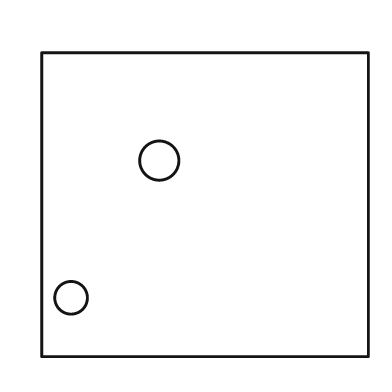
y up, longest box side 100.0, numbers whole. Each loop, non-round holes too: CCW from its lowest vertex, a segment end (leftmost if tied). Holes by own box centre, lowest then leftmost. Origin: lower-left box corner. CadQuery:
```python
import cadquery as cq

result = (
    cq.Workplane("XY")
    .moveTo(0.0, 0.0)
    .lineTo(100.0, 0.0)
    .lineTo(100.0, 93.0)
    .lineTo(0.0, 93.0)
    .close()
    .moveTo(9.0, 18.0)
    .circle(5.0)
    .moveTo(36.0, 60.0)
    .circle(6.0)
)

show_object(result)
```